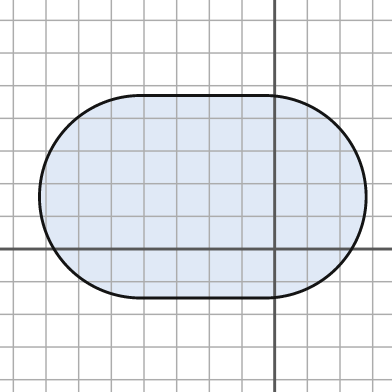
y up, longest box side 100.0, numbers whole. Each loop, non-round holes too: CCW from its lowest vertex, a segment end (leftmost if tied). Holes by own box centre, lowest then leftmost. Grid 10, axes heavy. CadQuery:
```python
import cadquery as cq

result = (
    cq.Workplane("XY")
    .moveTo(-41.0, -15.0)
    .lineTo(-3.0, -15.0)
    .threePointArc((28.0, 16.0), (-3.0, 47.0))
    .lineTo(-41.0, 47.0)
    .threePointArc((-72.0, 16.0), (-41.0, -15.0))
    .close()
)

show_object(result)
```